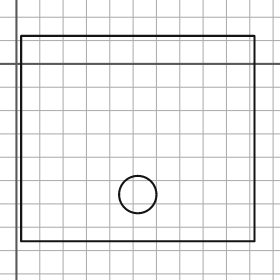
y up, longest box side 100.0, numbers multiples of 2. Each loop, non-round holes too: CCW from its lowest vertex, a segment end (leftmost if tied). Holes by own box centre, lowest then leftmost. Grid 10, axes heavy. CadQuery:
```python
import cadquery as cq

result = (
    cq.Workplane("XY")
    .moveTo(2.0, -76.0)
    .lineTo(102.0, -76.0)
    .lineTo(102.0, 12.0)
    .lineTo(2.0, 12.0)
    .close()
    .moveTo(52.0, -56.0)
    .circle(8.0)
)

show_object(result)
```